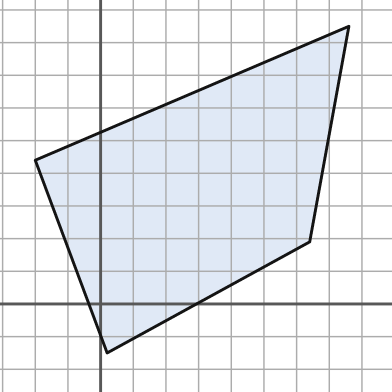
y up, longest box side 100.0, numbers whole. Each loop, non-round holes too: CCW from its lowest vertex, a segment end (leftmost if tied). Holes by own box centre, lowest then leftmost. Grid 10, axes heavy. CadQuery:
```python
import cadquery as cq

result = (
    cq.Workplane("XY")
    .moveTo(2.0, -15.0)
    .lineTo(64.0, 19.0)
    .lineTo(76.0, 85.0)
    .lineTo(-20.0, 44.0)
    .close()
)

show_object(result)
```